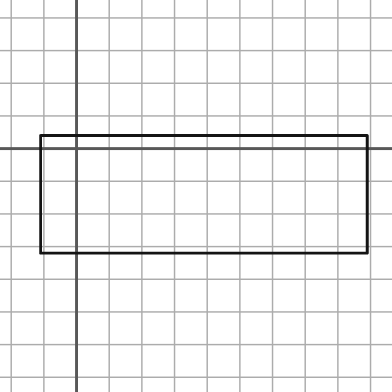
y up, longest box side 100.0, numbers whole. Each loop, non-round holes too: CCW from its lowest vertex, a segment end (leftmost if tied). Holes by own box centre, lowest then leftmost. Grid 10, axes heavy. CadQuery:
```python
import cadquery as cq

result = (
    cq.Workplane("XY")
    .moveTo(-11.0, -32.0)
    .lineTo(89.0, -32.0)
    .lineTo(89.0, 4.0)
    .lineTo(-11.0, 4.0)
    .close()
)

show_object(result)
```